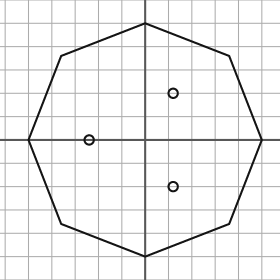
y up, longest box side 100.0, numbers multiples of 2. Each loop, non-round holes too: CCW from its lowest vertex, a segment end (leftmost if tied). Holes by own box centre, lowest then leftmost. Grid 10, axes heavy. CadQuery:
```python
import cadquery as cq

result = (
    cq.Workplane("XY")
    .moveTo(0.0, -50.0)
    .lineTo(36.0, -36.0)
    .lineTo(50.0, 0.0)
    .lineTo(36.0, 36.0)
    .lineTo(0.0, 50.0)
    .lineTo(-36.0, 36.0)
    .lineTo(-50.0, 0.0)
    .lineTo(-36.0, -36.0)
    .close()
    .moveTo(12.0, -20.0)
    .circle(2.0)
    .moveTo(-24.0, 0.0)
    .circle(2.0)
    .moveTo(12.0, 20.0)
    .circle(2.0)
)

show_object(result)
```